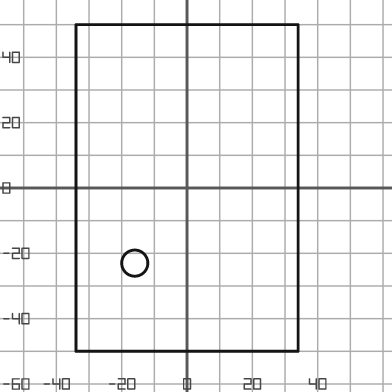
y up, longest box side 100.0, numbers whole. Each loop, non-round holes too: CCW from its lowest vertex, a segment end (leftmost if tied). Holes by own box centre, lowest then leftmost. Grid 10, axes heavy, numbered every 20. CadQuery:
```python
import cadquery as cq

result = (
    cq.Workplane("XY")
    .moveTo(-34.0, -50.0)
    .lineTo(34.0, -50.0)
    .lineTo(34.0, 50.0)
    .lineTo(-34.0, 50.0)
    .close()
    .moveTo(-16.0, -23.0)
    .circle(4.0)
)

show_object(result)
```